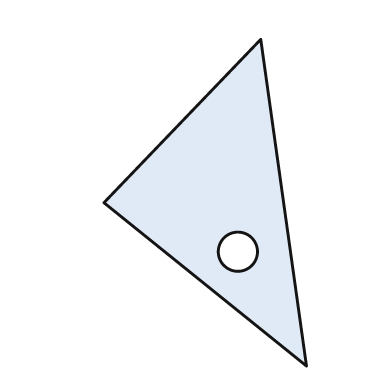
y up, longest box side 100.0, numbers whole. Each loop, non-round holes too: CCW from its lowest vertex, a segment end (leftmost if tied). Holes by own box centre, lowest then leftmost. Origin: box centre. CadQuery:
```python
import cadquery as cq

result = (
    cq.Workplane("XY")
    .moveTo(31.0, -50.0)
    .lineTo(17.0, 50.0)
    .lineTo(-31.0, 0.0)
    .close()
    .moveTo(10.0, -15.0)
    .circle(6.0)
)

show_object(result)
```